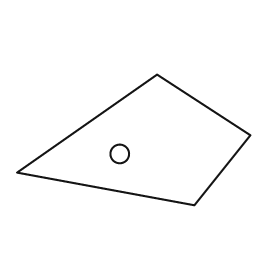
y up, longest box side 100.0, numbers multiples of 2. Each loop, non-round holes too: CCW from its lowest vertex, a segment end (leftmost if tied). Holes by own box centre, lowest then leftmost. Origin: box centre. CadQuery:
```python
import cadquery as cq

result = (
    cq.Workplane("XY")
    .moveTo(26.0, -28.0)
    .lineTo(50.0, 2.0)
    .lineTo(10.0, 28.0)
    .lineTo(-50.0, -14.0)
    .close()
    .moveTo(-6.0, -6.0)
    .circle(4.0)
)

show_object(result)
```